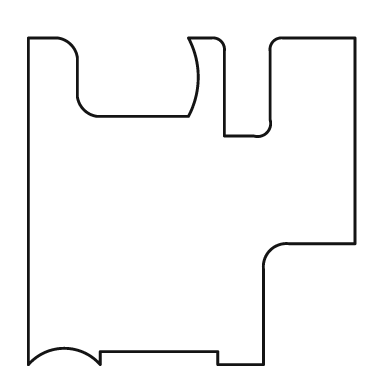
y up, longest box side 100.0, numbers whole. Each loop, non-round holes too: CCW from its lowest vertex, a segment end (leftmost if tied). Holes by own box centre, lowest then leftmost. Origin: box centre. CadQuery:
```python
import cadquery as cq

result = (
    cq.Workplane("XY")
    .moveTo(-50.0, -50.0)
    .threePointArc((-39.0, -45.0), (-28.0, -50.0))
    .lineTo(-28.0, -46.0)
    .lineTo(8.0, -46.0)
    .lineTo(8.0, -50.0)
    .lineTo(22.0, -50.0)
    .lineTo(22.0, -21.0)
    .threePointArc((24.0, -15.0), (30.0, -13.0))
    .lineTo(50.0, -13.0)
    .lineTo(50.0, 50.0)
    .lineTo(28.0, 50.0)
    .threePointArc((25.0, 49.0), (24.0, 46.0))
    .lineTo(24.0, 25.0)
    .threePointArc((23.0, 21.0), (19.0, 20.0))
    .lineTo(10.0, 20.0)
    .lineTo(10.0, 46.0)
    .threePointArc((9.0, 49.0), (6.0, 50.0))
    .lineTo(-1.0, 50.0)
    .threePointArc((2.0, 38.0), (-1.0, 26.0))
    .lineTo(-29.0, 26.0)
    .threePointArc((-33.0, 28.0), (-35.0, 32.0))
    .lineTo(-35.0, 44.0)
    .threePointArc((-37.0, 48.0), (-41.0, 50.0))
    .lineTo(-50.0, 50.0)
    .close()
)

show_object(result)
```